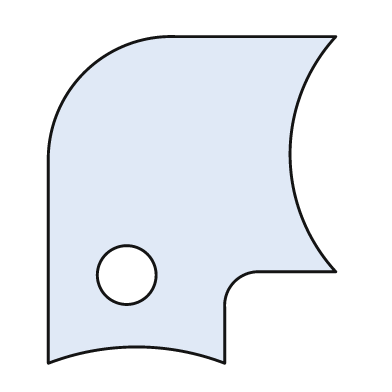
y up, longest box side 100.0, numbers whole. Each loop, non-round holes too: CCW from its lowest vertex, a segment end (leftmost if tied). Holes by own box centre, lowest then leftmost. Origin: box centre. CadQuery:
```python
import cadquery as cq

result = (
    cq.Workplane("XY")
    .moveTo(-44.0, -50.0)
    .threePointArc((-17.0, -45.0), (10.0, -50.0))
    .lineTo(10.0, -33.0)
    .threePointArc((13.0, -25.0), (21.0, -22.0))
    .lineTo(44.0, -22.0)
    .threePointArc((30.0, 14.0), (44.0, 50.0))
    .lineTo(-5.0, 50.0)
    .threePointArc((-33.0, 39.0), (-44.0, 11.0))
    .close()
    .moveTo(-20.0, -23.0)
    .circle(9.0)
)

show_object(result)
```